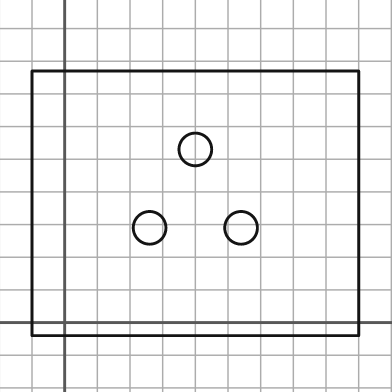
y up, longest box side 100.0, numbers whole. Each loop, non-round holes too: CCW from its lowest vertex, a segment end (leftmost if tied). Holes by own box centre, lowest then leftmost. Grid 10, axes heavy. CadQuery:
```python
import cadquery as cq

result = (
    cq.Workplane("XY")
    .moveTo(-10.0, -4.0)
    .lineTo(90.0, -4.0)
    .lineTo(90.0, 77.0)
    .lineTo(-10.0, 77.0)
    .close()
    .moveTo(26.0, 29.0)
    .circle(5.0)
    .moveTo(54.0, 29.0)
    .circle(5.0)
    .moveTo(40.0, 53.0)
    .circle(5.0)
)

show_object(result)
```